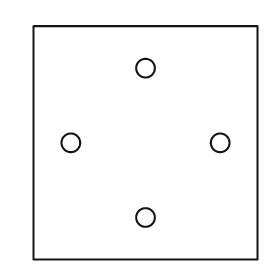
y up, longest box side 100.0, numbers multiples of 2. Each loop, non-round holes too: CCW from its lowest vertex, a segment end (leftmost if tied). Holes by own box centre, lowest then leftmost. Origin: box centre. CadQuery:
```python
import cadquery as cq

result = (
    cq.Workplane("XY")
    .moveTo(-48.0, -50.0)
    .lineTo(48.0, -50.0)
    .lineTo(48.0, 50.0)
    .lineTo(-48.0, 50.0)
    .close()
    .moveTo(0.0, -32.0)
    .circle(4.0)
    .moveTo(-32.0, 0.0)
    .circle(4.0)
    .moveTo(32.0, 0.0)
    .circle(4.0)
    .moveTo(0.0, 32.0)
    .circle(4.0)
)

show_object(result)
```